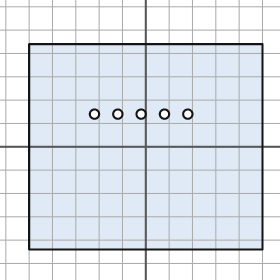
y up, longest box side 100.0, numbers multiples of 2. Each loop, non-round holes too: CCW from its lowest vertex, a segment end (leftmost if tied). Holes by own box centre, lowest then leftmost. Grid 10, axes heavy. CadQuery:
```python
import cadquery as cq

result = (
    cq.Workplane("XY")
    .moveTo(-50.0, -44.0)
    .lineTo(50.0, -44.0)
    .lineTo(50.0, 44.0)
    .lineTo(-50.0, 44.0)
    .close()
    .moveTo(-22.0, 14.0)
    .circle(2.0)
    .moveTo(-12.0, 14.0)
    .circle(2.0)
    .moveTo(-2.0, 14.0)
    .circle(2.0)
    .moveTo(8.0, 14.0)
    .circle(2.0)
    .moveTo(18.0, 14.0)
    .circle(2.0)
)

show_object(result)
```